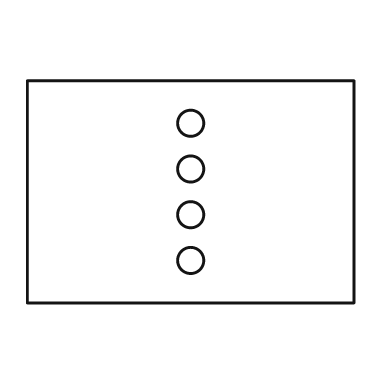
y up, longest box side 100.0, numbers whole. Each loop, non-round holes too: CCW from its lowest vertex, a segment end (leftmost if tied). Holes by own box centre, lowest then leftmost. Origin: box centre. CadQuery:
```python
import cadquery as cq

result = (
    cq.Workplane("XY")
    .moveTo(-50.0, -34.0)
    .lineTo(50.0, -34.0)
    .lineTo(50.0, 34.0)
    .lineTo(-50.0, 34.0)
    .close()
    .moveTo(0.0, -21.0)
    .circle(4.0)
    .moveTo(0.0, -7.0)
    .circle(4.0)
    .moveTo(0.0, 7.0)
    .circle(4.0)
    .moveTo(0.0, 21.0)
    .circle(4.0)
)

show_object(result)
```